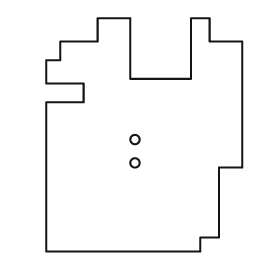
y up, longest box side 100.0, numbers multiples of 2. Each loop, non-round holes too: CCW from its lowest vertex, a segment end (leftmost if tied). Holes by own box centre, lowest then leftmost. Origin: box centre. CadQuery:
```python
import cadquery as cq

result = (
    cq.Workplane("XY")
    .moveTo(-42.0, -50.0)
    .lineTo(24.0, -50.0)
    .lineTo(24.0, -44.0)
    .lineTo(32.0, -44.0)
    .lineTo(32.0, -14.0)
    .lineTo(42.0, -14.0)
    .lineTo(42.0, 40.0)
    .lineTo(28.0, 40.0)
    .lineTo(28.0, 50.0)
    .lineTo(20.0, 50.0)
    .lineTo(20.0, 24.0)
    .lineTo(-6.0, 24.0)
    .lineTo(-6.0, 50.0)
    .lineTo(-20.0, 50.0)
    .lineTo(-20.0, 40.0)
    .lineTo(-36.0, 40.0)
    .lineTo(-36.0, 32.0)
    .lineTo(-42.0, 32.0)
    .lineTo(-42.0, 22.0)
    .lineTo(-26.0, 22.0)
    .lineTo(-26.0, 14.0)
    .lineTo(-42.0, 14.0)
    .close()
    .moveTo(-4.0, -12.0)
    .circle(2.0)
    .moveTo(-4.0, -2.0)
    .circle(2.0)
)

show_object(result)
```